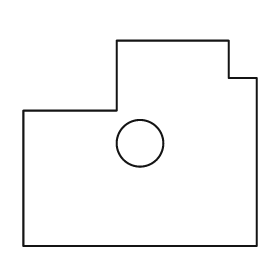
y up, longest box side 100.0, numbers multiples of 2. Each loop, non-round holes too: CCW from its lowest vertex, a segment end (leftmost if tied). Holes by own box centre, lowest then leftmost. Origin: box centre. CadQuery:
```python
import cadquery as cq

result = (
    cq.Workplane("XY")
    .moveTo(-50.0, -44.0)
    .lineTo(50.0, -44.0)
    .lineTo(50.0, 28.0)
    .lineTo(38.0, 28.0)
    .lineTo(38.0, 44.0)
    .lineTo(-10.0, 44.0)
    .lineTo(-10.0, 14.0)
    .lineTo(-50.0, 14.0)
    .close()
    .moveTo(0.0, 0.0)
    .circle(10.0)
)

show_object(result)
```